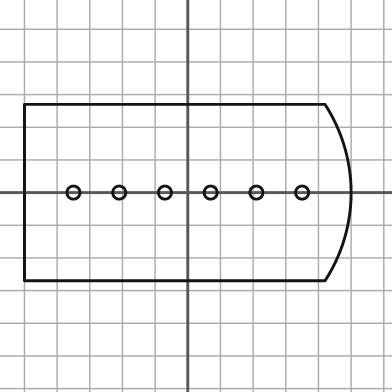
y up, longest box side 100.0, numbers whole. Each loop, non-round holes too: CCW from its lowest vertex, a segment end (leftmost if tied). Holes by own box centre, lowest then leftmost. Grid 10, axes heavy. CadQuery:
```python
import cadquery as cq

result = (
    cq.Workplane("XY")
    .moveTo(-50.0, -27.0)
    .lineTo(42.0, -27.0)
    .threePointArc((50.0, 0.0), (42.0, 27.0))
    .lineTo(-50.0, 27.0)
    .close()
    .moveTo(-35.0, 0.0)
    .circle(2.0)
    .moveTo(-21.0, 0.0)
    .circle(2.0)
    .moveTo(-7.0, 0.0)
    .circle(2.0)
    .moveTo(7.0, 0.0)
    .circle(2.0)
    .moveTo(21.0, 0.0)
    .circle(2.0)
    .moveTo(35.0, 0.0)
    .circle(2.0)
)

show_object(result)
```